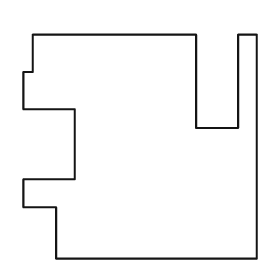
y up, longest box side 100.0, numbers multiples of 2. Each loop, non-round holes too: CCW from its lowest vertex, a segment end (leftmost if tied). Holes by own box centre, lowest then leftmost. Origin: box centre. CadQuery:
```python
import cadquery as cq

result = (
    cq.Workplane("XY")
    .moveTo(-36.0, -48.0)
    .lineTo(50.0, -48.0)
    .lineTo(50.0, 48.0)
    .lineTo(42.0, 48.0)
    .lineTo(42.0, 8.0)
    .lineTo(24.0, 8.0)
    .lineTo(24.0, 48.0)
    .lineTo(-46.0, 48.0)
    .lineTo(-46.0, 32.0)
    .lineTo(-50.0, 32.0)
    .lineTo(-50.0, 16.0)
    .lineTo(-28.0, 16.0)
    .lineTo(-28.0, -14.0)
    .lineTo(-50.0, -14.0)
    .lineTo(-50.0, -26.0)
    .lineTo(-36.0, -26.0)
    .close()
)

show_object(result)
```